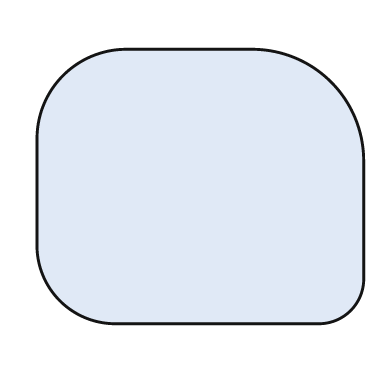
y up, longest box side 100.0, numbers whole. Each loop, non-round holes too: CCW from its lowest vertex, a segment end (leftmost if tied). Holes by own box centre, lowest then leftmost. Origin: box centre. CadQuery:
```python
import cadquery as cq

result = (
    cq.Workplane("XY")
    .moveTo(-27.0, -42.0)
    .lineTo(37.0, -42.0)
    .threePointArc((46.0, -38.0), (50.0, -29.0))
    .lineTo(50.0, 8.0)
    .threePointArc((40.0, 32.0), (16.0, 42.0))
    .lineTo(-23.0, 42.0)
    .threePointArc((-42.0, 34.0), (-50.0, 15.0))
    .lineTo(-50.0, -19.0)
    .threePointArc((-43.0, -35.0), (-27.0, -42.0))
    .close()
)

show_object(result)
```